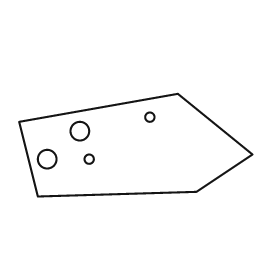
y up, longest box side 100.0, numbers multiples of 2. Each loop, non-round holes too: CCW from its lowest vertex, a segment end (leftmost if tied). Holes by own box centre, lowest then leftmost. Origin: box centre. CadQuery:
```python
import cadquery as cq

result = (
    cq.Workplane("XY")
    .moveTo(-42.0, -22.0)
    .lineTo(26.0, -20.0)
    .lineTo(50.0, -4.0)
    .lineTo(18.0, 22.0)
    .lineTo(-50.0, 10.0)
    .close()
    .moveTo(-38.0, -6.0)
    .circle(4.0)
    .moveTo(-20.0, -6.0)
    .circle(2.0)
    .moveTo(-24.0, 6.0)
    .circle(4.0)
    .moveTo(6.0, 12.0)
    .circle(2.0)
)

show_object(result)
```